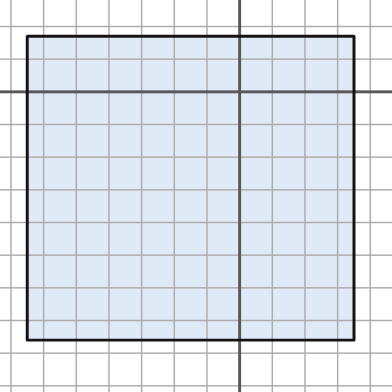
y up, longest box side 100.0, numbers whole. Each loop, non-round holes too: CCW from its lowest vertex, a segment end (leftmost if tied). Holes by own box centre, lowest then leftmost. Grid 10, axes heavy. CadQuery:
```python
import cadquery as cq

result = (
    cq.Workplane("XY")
    .moveTo(-65.0, -76.0)
    .lineTo(35.0, -76.0)
    .lineTo(35.0, 17.0)
    .lineTo(-65.0, 17.0)
    .close()
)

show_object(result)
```